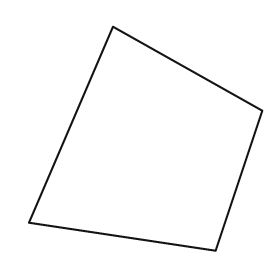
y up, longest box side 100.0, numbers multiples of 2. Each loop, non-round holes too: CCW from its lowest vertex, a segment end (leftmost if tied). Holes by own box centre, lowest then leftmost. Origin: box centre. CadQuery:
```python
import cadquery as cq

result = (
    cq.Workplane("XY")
    .moveTo(30.0, -48.0)
    .lineTo(50.0, 12.0)
    .lineTo(-14.0, 48.0)
    .lineTo(-50.0, -36.0)
    .close()
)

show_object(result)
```